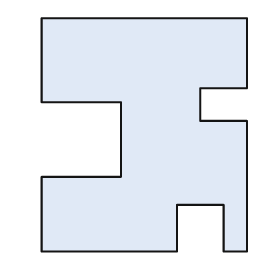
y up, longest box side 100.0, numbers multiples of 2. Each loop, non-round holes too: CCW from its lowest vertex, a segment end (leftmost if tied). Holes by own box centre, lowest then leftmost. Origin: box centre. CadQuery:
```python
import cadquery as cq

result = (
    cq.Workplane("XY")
    .moveTo(-44.0, -50.0)
    .lineTo(14.0, -50.0)
    .lineTo(14.0, -30.0)
    .lineTo(34.0, -30.0)
    .lineTo(34.0, -50.0)
    .lineTo(44.0, -50.0)
    .lineTo(44.0, 6.0)
    .lineTo(24.0, 6.0)
    .lineTo(24.0, 20.0)
    .lineTo(44.0, 20.0)
    .lineTo(44.0, 50.0)
    .lineTo(-44.0, 50.0)
    .lineTo(-44.0, 14.0)
    .lineTo(-10.0, 14.0)
    .lineTo(-10.0, -18.0)
    .lineTo(-44.0, -18.0)
    .close()
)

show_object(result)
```